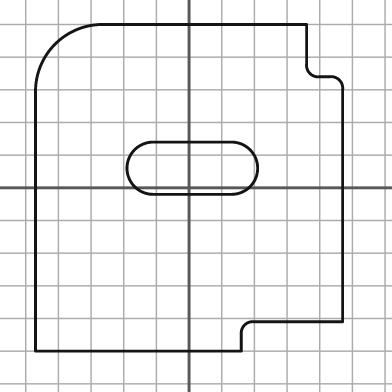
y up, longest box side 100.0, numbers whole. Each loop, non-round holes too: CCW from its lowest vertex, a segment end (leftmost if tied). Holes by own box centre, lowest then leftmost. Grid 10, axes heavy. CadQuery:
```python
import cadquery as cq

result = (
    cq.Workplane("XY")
    .moveTo(-47.0, -50.0)
    .lineTo(16.0, -50.0)
    .lineTo(16.0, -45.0)
    .threePointArc((17.0, -42.0), (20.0, -41.0))
    .lineTo(47.0, -41.0)
    .lineTo(47.0, 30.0)
    .threePointArc((46.0, 33.0), (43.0, 34.0))
    .lineTo(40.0, 34.0)
    .threePointArc((37.0, 35.0), (36.0, 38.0))
    .lineTo(36.0, 50.0)
    .lineTo(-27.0, 50.0)
    .threePointArc((-41.0, 44.0), (-47.0, 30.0))
    .close()
    .moveTo(-11.0, -2.0)
    .lineTo(13.0, -2.0)
    .threePointArc((21.0, 6.0), (13.0, 14.0))
    .lineTo(-11.0, 14.0)
    .threePointArc((-19.0, 6.0), (-11.0, -2.0))
    .close()
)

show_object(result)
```